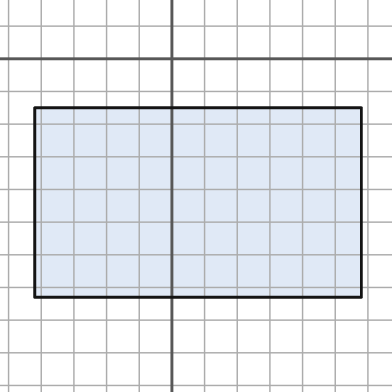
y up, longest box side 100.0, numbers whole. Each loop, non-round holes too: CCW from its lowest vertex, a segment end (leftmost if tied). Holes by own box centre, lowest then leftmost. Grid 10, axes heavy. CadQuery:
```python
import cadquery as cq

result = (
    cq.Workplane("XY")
    .moveTo(-42.0, -73.0)
    .lineTo(58.0, -73.0)
    .lineTo(58.0, -15.0)
    .lineTo(-42.0, -15.0)
    .close()
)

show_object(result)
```